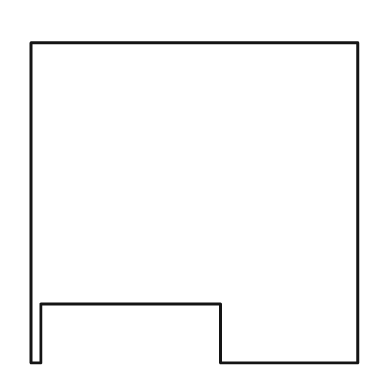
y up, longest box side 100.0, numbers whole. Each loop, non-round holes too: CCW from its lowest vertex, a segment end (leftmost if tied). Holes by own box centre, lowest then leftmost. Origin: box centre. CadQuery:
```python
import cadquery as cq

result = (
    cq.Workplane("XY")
    .moveTo(-50.0, -49.0)
    .lineTo(-47.0, -49.0)
    .lineTo(-47.0, -31.0)
    .lineTo(8.0, -31.0)
    .lineTo(8.0, -49.0)
    .lineTo(50.0, -49.0)
    .lineTo(50.0, 49.0)
    .lineTo(-50.0, 49.0)
    .close()
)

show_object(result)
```